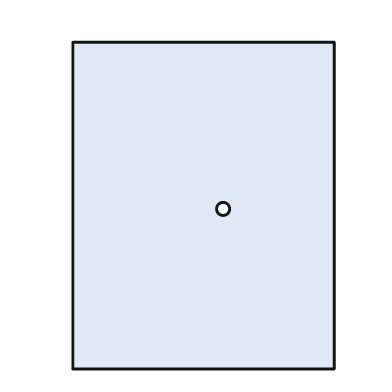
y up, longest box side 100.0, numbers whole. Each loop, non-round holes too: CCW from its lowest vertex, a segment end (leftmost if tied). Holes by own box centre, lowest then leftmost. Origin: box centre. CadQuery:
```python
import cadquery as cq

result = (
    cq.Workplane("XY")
    .moveTo(-40.0, -50.0)
    .lineTo(40.0, -50.0)
    .lineTo(40.0, 50.0)
    .lineTo(-40.0, 50.0)
    .close()
    .moveTo(6.0, -1.0)
    .circle(2.0)
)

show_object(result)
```